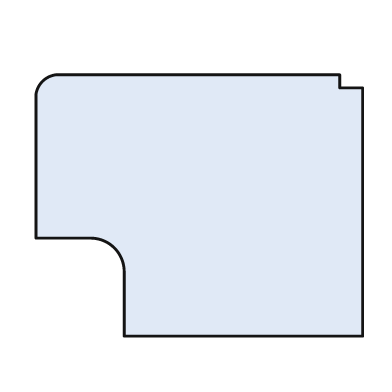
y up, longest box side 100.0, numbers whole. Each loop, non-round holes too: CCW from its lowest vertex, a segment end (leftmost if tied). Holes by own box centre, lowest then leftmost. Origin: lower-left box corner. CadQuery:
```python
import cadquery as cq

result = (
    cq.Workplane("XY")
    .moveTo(27.0, 0.0)
    .lineTo(100.0, 0.0)
    .lineTo(100.0, 76.0)
    .lineTo(93.0, 76.0)
    .lineTo(93.0, 80.0)
    .lineTo(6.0, 80.0)
    .threePointArc((2.0, 78.0), (0.0, 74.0))
    .lineTo(0.0, 30.0)
    .lineTo(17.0, 30.0)
    .threePointArc((24.0, 27.0), (27.0, 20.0))
    .close()
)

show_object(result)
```